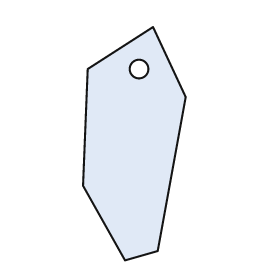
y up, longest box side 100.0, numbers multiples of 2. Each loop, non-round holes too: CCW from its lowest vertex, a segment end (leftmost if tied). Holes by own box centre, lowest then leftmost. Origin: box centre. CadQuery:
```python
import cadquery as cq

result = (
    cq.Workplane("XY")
    .moveTo(-4.0, -50.0)
    .lineTo(10.0, -46.0)
    .lineTo(22.0, 20.0)
    .lineTo(8.0, 50.0)
    .lineTo(-20.0, 32.0)
    .lineTo(-22.0, -18.0)
    .close()
    .moveTo(2.0, 32.0)
    .circle(4.0)
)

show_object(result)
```